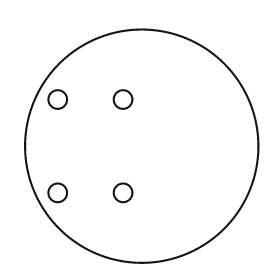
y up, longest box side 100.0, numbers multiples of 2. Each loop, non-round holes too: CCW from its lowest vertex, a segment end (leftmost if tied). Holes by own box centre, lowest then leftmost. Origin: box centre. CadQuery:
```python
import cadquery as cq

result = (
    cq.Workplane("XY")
    .moveTo(0.0, 0.0)
    .circle(50.0)
    .moveTo(-36.0, -20.0)
    .circle(4.0)
    .moveTo(-8.0, -20.0)
    .circle(4.0)
    .moveTo(-36.0, 20.0)
    .circle(4.0)
    .moveTo(-8.0, 20.0)
    .circle(4.0)
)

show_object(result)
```